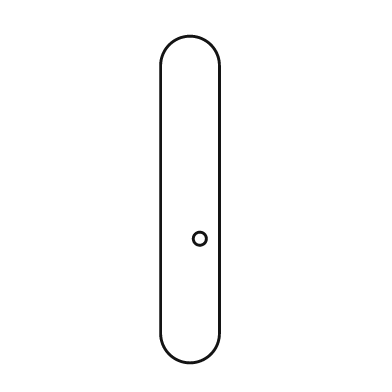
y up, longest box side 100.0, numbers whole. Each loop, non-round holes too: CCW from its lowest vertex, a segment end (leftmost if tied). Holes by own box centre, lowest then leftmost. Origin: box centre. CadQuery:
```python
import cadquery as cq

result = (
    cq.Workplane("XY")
    .moveTo(-9.0, -41.0)
    .threePointArc((0.0, -50.0), (9.0, -41.0))
    .lineTo(9.0, 41.0)
    .threePointArc((0.0, 50.0), (-9.0, 41.0))
    .close()
    .moveTo(3.0, -12.0)
    .circle(2.0)
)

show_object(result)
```